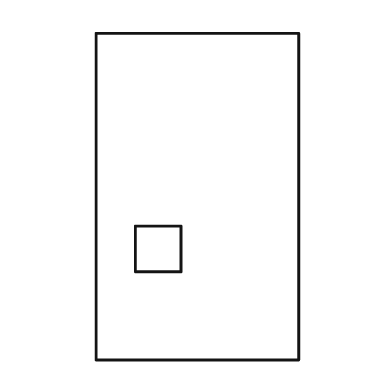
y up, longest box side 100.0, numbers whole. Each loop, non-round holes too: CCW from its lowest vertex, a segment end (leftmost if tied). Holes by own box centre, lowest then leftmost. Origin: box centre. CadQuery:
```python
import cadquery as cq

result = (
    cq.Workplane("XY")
    .moveTo(-31.0, -50.0)
    .lineTo(31.0, -50.0)
    .lineTo(31.0, 50.0)
    .lineTo(-31.0, 50.0)
    .close()
    .moveTo(-19.0, -23.0)
    .lineTo(-5.0, -23.0)
    .lineTo(-5.0, -9.0)
    .lineTo(-19.0, -9.0)
    .close()
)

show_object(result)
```